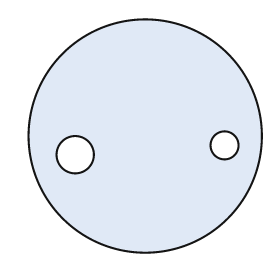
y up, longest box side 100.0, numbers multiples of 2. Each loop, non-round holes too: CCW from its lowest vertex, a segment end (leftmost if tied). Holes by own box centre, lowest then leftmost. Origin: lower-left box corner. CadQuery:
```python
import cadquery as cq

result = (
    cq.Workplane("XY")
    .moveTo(50.0, 50.0)
    .circle(50.0)
    .moveTo(20.0, 42.0)
    .circle(8.0)
    .moveTo(84.0, 46.0)
    .circle(6.0)
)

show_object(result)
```